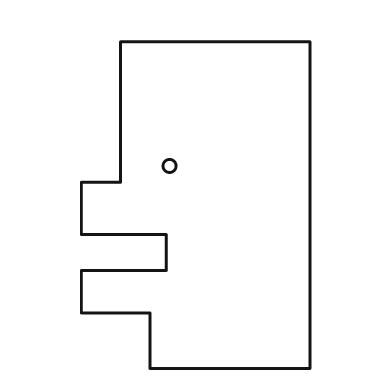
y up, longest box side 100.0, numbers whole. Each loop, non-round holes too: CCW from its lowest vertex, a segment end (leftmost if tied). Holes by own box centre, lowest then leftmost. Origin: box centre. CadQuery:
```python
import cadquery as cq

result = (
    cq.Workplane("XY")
    .moveTo(-14.0, -50.0)
    .lineTo(35.0, -50.0)
    .lineTo(35.0, 50.0)
    .lineTo(-23.0, 50.0)
    .lineTo(-23.0, 7.0)
    .lineTo(-35.0, 7.0)
    .lineTo(-35.0, -9.0)
    .lineTo(-9.0, -9.0)
    .lineTo(-9.0, -20.0)
    .lineTo(-35.0, -20.0)
    .lineTo(-35.0, -33.0)
    .lineTo(-14.0, -33.0)
    .close()
    .moveTo(-8.0, 12.0)
    .circle(2.0)
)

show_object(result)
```